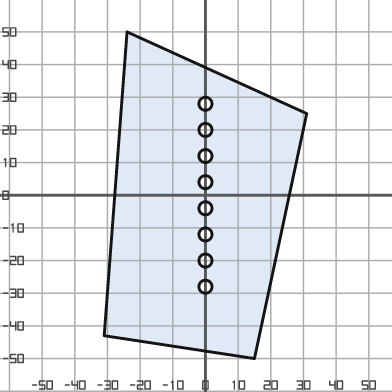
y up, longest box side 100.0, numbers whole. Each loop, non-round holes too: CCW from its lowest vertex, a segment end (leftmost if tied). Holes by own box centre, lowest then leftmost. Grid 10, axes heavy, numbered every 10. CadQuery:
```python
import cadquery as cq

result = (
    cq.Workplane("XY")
    .moveTo(15.0, -50.0)
    .lineTo(31.0, 25.0)
    .lineTo(-24.0, 50.0)
    .lineTo(-31.0, -43.0)
    .close()
    .moveTo(0.0, -28.0)
    .circle(2.0)
    .moveTo(0.0, -20.0)
    .circle(2.0)
    .moveTo(0.0, -12.0)
    .circle(2.0)
    .moveTo(0.0, -4.0)
    .circle(2.0)
    .moveTo(0.0, 4.0)
    .circle(2.0)
    .moveTo(0.0, 12.0)
    .circle(2.0)
    .moveTo(0.0, 20.0)
    .circle(2.0)
    .moveTo(0.0, 28.0)
    .circle(2.0)
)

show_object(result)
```